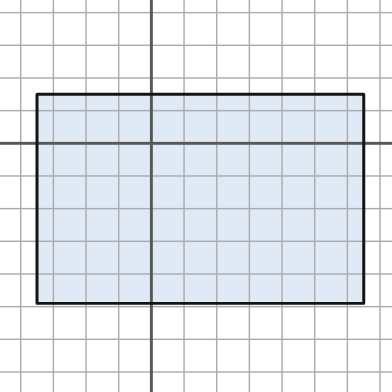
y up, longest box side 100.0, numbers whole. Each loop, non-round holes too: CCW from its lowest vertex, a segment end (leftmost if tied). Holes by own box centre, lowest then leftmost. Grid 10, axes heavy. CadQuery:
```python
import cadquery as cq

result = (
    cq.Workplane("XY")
    .moveTo(-35.0, -49.0)
    .lineTo(65.0, -49.0)
    .lineTo(65.0, 15.0)
    .lineTo(-35.0, 15.0)
    .close()
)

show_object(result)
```